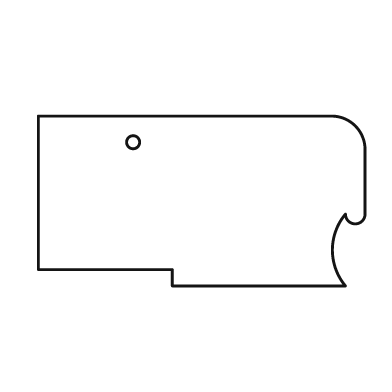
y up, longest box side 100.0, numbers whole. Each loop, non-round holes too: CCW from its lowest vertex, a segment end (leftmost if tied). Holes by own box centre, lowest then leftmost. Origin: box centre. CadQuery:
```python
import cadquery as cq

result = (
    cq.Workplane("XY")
    .moveTo(-9.0, -26.0)
    .lineTo(44.0, -26.0)
    .threePointArc((40.0, -15.0), (44.0, -4.0))
    .threePointArc((47.0, -7.0), (50.0, -4.0))
    .lineTo(50.0, 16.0)
    .threePointArc((47.0, 23.0), (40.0, 26.0))
    .lineTo(-50.0, 26.0)
    .lineTo(-50.0, -21.0)
    .lineTo(-9.0, -21.0)
    .close()
    .moveTo(-21.0, 18.0)
    .circle(2.0)
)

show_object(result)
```